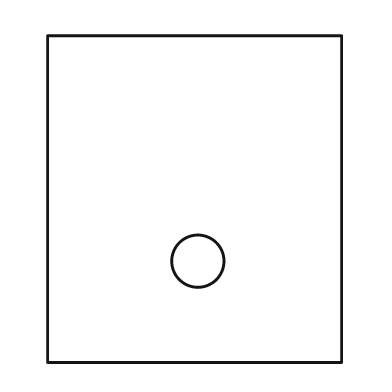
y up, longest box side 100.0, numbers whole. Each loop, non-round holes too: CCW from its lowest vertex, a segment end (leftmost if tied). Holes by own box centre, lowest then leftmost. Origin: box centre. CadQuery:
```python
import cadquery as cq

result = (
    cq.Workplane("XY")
    .moveTo(-45.0, -50.0)
    .lineTo(45.0, -50.0)
    .lineTo(45.0, 50.0)
    .lineTo(-45.0, 50.0)
    .close()
    .moveTo(1.0, -19.0)
    .circle(8.0)
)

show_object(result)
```